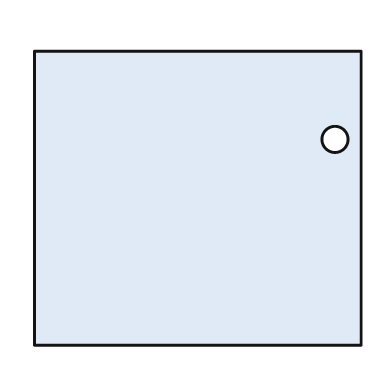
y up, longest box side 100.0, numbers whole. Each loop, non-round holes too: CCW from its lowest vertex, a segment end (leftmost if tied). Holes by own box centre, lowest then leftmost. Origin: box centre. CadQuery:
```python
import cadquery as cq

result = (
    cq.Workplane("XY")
    .moveTo(-50.0, -45.0)
    .lineTo(50.0, -45.0)
    .lineTo(50.0, 45.0)
    .lineTo(-50.0, 45.0)
    .close()
    .moveTo(42.0, 18.0)
    .circle(4.0)
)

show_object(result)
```